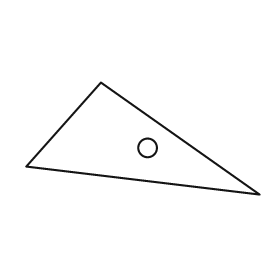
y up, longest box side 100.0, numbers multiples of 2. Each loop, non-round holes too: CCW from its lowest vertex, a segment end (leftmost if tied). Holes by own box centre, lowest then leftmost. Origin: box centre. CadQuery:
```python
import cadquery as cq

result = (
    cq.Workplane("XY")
    .moveTo(50.0, -24.0)
    .lineTo(-18.0, 24.0)
    .lineTo(-50.0, -12.0)
    .close()
    .moveTo(2.0, -4.0)
    .circle(4.0)
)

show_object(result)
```